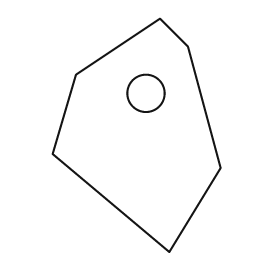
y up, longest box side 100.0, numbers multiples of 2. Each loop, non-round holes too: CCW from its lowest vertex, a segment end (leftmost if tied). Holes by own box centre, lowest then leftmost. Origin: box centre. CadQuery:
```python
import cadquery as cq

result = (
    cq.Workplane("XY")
    .moveTo(14.0, -50.0)
    .lineTo(36.0, -14.0)
    .lineTo(22.0, 38.0)
    .lineTo(10.0, 50.0)
    .lineTo(-26.0, 26.0)
    .lineTo(-36.0, -8.0)
    .close()
    .moveTo(4.0, 18.0)
    .circle(8.0)
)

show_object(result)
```